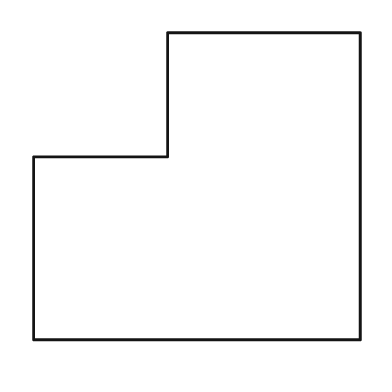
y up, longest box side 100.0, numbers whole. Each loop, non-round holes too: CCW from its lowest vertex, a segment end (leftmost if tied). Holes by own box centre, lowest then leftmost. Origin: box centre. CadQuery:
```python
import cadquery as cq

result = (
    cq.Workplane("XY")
    .moveTo(-50.0, -47.0)
    .lineTo(50.0, -47.0)
    .lineTo(50.0, 47.0)
    .lineTo(-9.0, 47.0)
    .lineTo(-9.0, 9.0)
    .lineTo(-50.0, 9.0)
    .close()
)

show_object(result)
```